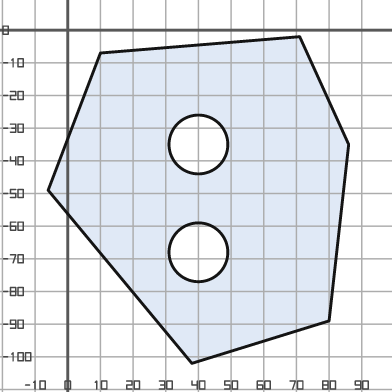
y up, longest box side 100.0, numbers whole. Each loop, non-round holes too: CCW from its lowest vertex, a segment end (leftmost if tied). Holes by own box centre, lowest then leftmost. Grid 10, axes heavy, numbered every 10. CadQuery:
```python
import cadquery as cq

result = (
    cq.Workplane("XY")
    .moveTo(38.0, -102.0)
    .lineTo(80.0, -89.0)
    .lineTo(86.0, -35.0)
    .lineTo(71.0, -2.0)
    .lineTo(10.0, -7.0)
    .lineTo(-6.0, -49.0)
    .close()
    .moveTo(40.0, -68.0)
    .circle(9.0)
    .moveTo(40.0, -35.0)
    .circle(9.0)
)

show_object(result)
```